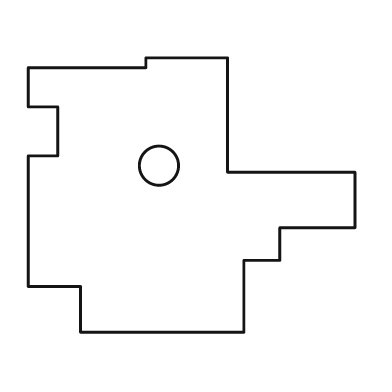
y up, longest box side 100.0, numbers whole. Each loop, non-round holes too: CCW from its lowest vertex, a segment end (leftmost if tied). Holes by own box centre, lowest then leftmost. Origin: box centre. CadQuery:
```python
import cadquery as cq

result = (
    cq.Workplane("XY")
    .moveTo(-34.0, -42.0)
    .lineTo(16.0, -42.0)
    .lineTo(16.0, -20.0)
    .lineTo(27.0, -20.0)
    .lineTo(27.0, -10.0)
    .lineTo(50.0, -10.0)
    .lineTo(50.0, 7.0)
    .lineTo(11.0, 7.0)
    .lineTo(11.0, 42.0)
    .lineTo(-14.0, 42.0)
    .lineTo(-14.0, 39.0)
    .lineTo(-50.0, 39.0)
    .lineTo(-50.0, 27.0)
    .lineTo(-41.0, 27.0)
    .lineTo(-41.0, 12.0)
    .lineTo(-50.0, 12.0)
    .lineTo(-50.0, -28.0)
    .lineTo(-34.0, -28.0)
    .close()
    .moveTo(-10.0, 9.0)
    .circle(6.0)
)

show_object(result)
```